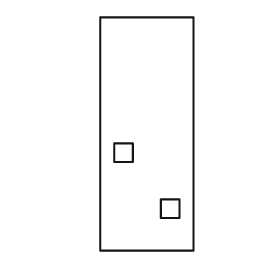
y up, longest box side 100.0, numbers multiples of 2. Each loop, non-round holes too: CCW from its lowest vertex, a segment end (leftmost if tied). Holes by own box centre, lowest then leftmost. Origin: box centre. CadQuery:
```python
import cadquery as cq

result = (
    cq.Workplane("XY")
    .moveTo(-20.0, -50.0)
    .lineTo(20.0, -50.0)
    .lineTo(20.0, 50.0)
    .lineTo(-20.0, 50.0)
    .close()
    .moveTo(6.0, -36.0)
    .lineTo(14.0, -36.0)
    .lineTo(14.0, -28.0)
    .lineTo(6.0, -28.0)
    .close()
    .moveTo(-14.0, -12.0)
    .lineTo(-6.0, -12.0)
    .lineTo(-6.0, -4.0)
    .lineTo(-14.0, -4.0)
    .close()
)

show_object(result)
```